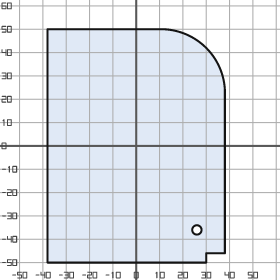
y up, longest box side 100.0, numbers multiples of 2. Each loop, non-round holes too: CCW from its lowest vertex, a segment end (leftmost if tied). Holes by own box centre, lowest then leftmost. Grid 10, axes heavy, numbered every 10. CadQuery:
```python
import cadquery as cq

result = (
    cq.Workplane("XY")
    .moveTo(-38.0, -50.0)
    .lineTo(30.0, -50.0)
    .lineTo(30.0, -46.0)
    .lineTo(38.0, -46.0)
    .lineTo(38.0, 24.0)
    .threePointArc((30.0, 42.0), (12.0, 50.0))
    .lineTo(-38.0, 50.0)
    .close()
    .moveTo(26.0, -36.0)
    .circle(2.0)
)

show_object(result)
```